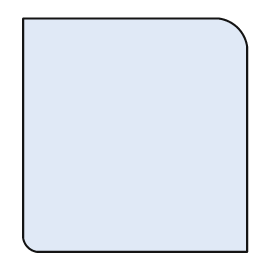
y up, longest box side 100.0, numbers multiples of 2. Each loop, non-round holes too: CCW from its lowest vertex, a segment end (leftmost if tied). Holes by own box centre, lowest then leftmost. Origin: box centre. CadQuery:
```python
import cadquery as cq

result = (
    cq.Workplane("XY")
    .moveTo(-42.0, -50.0)
    .lineTo(48.0, -50.0)
    .lineTo(48.0, 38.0)
    .threePointArc((44.0, 46.0), (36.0, 50.0))
    .lineTo(-48.0, 50.0)
    .lineTo(-48.0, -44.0)
    .threePointArc((-46.0, -48.0), (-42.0, -50.0))
    .close()
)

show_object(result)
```